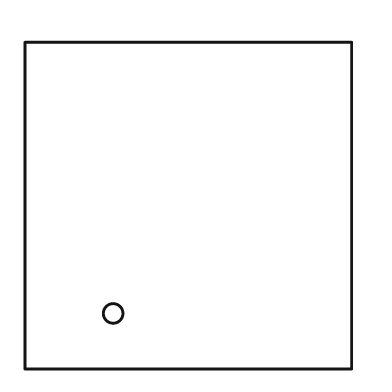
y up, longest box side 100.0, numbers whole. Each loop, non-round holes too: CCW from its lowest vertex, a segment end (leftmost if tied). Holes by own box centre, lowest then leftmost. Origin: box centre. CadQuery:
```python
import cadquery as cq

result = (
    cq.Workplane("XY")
    .moveTo(-50.0, -50.0)
    .lineTo(50.0, -50.0)
    .lineTo(50.0, 50.0)
    .lineTo(-50.0, 50.0)
    .close()
    .moveTo(-23.0, -33.0)
    .circle(3.0)
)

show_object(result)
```